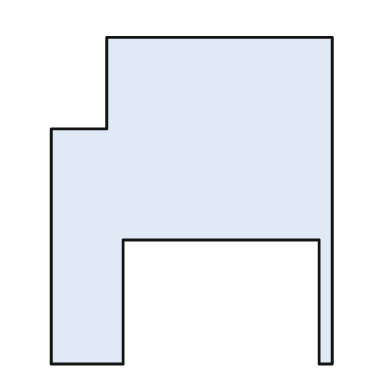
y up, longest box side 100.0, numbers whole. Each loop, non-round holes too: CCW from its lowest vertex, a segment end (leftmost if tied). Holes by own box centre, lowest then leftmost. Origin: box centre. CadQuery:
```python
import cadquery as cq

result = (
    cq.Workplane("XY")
    .moveTo(-43.0, -50.0)
    .lineTo(-21.0, -50.0)
    .lineTo(-21.0, -12.0)
    .lineTo(39.0, -12.0)
    .lineTo(39.0, -50.0)
    .lineTo(43.0, -50.0)
    .lineTo(43.0, 50.0)
    .lineTo(-26.0, 50.0)
    .lineTo(-26.0, 22.0)
    .lineTo(-43.0, 22.0)
    .close()
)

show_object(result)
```